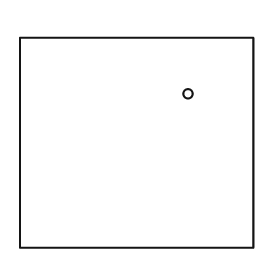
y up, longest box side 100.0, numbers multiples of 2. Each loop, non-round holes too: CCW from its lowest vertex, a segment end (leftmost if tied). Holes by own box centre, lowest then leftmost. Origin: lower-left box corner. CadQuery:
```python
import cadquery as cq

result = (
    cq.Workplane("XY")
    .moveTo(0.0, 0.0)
    .lineTo(100.0, 0.0)
    .lineTo(100.0, 90.0)
    .lineTo(0.0, 90.0)
    .close()
    .moveTo(72.0, 66.0)
    .circle(2.0)
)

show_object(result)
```